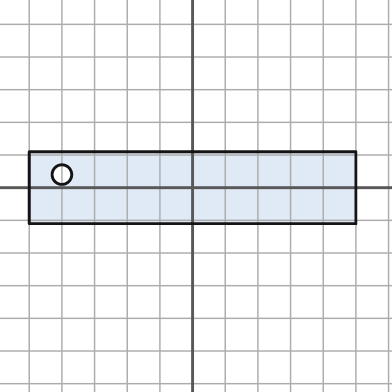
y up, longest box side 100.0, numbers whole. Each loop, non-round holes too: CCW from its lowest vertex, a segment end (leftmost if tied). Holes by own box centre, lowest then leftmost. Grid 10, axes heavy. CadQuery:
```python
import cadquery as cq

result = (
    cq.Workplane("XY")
    .moveTo(-50.0, -11.0)
    .lineTo(50.0, -11.0)
    .lineTo(50.0, 11.0)
    .lineTo(-50.0, 11.0)
    .close()
    .moveTo(-40.0, 4.0)
    .circle(3.0)
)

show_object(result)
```